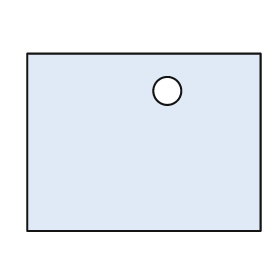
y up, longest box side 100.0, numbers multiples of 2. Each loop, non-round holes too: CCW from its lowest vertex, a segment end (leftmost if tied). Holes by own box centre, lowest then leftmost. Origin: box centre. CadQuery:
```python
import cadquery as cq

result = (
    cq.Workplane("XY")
    .moveTo(-50.0, -38.0)
    .lineTo(50.0, -38.0)
    .lineTo(50.0, 38.0)
    .lineTo(-50.0, 38.0)
    .close()
    .moveTo(10.0, 22.0)
    .circle(6.0)
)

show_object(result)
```